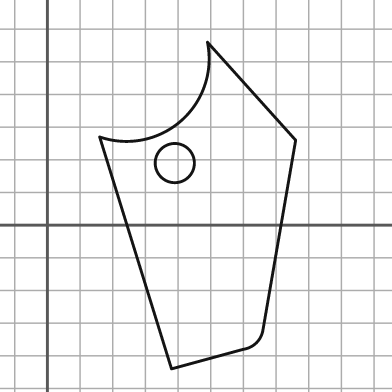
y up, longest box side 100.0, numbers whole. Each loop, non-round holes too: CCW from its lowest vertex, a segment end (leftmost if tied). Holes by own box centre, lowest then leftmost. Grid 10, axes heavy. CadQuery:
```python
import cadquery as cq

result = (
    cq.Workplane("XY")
    .moveTo(38.0, -44.0)
    .lineTo(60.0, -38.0)
    .threePointArc((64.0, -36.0), (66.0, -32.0))
    .lineTo(76.0, 26.0)
    .lineTo(49.0, 56.0)
    .threePointArc((41.0, 32.0), (16.0, 27.0))
    .close()
    .moveTo(39.0, 19.0)
    .circle(6.0)
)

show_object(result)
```